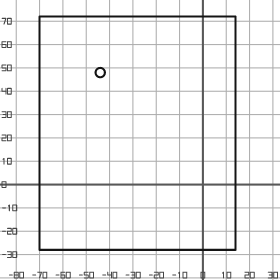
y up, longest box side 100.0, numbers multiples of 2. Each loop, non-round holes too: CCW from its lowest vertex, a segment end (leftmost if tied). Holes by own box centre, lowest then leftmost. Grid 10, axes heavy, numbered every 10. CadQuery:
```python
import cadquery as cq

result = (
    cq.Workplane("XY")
    .moveTo(-70.0, -28.0)
    .lineTo(14.0, -28.0)
    .lineTo(14.0, 72.0)
    .lineTo(-70.0, 72.0)
    .close()
    .moveTo(-44.0, 48.0)
    .circle(2.0)
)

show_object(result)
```